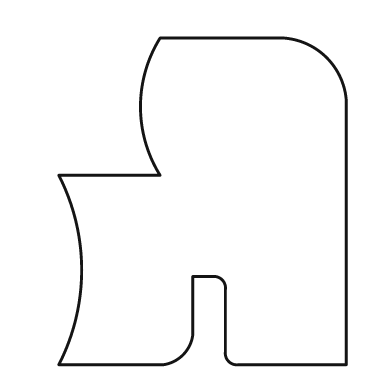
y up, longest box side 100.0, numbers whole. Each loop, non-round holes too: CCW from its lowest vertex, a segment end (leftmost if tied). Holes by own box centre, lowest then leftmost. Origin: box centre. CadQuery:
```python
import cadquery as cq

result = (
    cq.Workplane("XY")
    .moveTo(-44.0, -50.0)
    .lineTo(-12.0, -50.0)
    .threePointArc((-6.0, -47.0), (-3.0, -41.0))
    .lineTo(-3.0, -23.0)
    .lineTo(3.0, -23.0)
    .threePointArc((6.0, -24.0), (7.0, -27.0))
    .lineTo(7.0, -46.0)
    .threePointArc((8.0, -49.0), (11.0, -50.0))
    .lineTo(44.0, -50.0)
    .lineTo(44.0, 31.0)
    .threePointArc((38.0, 44.0), (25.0, 50.0))
    .lineTo(-13.0, 50.0)
    .threePointArc((-19.0, 29.0), (-13.0, 8.0))
    .lineTo(-44.0, 8.0)
    .threePointArc((-37.0, -21.0), (-44.0, -50.0))
    .close()
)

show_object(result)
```